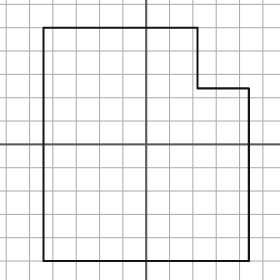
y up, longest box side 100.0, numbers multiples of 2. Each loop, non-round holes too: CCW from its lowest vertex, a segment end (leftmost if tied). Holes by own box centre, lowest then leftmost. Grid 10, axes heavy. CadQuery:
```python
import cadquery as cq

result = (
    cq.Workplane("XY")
    .moveTo(-44.0, -50.0)
    .lineTo(44.0, -50.0)
    .lineTo(44.0, 24.0)
    .lineTo(22.0, 24.0)
    .lineTo(22.0, 50.0)
    .lineTo(-44.0, 50.0)
    .close()
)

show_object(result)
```